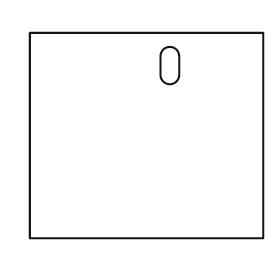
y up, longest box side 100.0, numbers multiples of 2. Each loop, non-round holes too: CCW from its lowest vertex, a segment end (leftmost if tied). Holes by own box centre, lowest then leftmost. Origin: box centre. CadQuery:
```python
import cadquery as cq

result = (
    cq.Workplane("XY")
    .moveTo(-50.0, -44.0)
    .lineTo(50.0, -44.0)
    .lineTo(50.0, 44.0)
    .lineTo(-50.0, 44.0)
    .close()
    .moveTo(6.0, 26.0)
    .threePointArc((10.0, 22.0), (14.0, 26.0))
    .lineTo(14.0, 34.0)
    .threePointArc((10.0, 38.0), (6.0, 34.0))
    .close()
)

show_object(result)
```